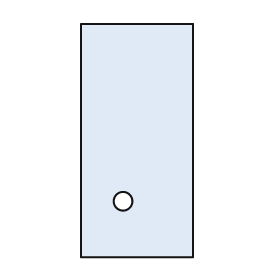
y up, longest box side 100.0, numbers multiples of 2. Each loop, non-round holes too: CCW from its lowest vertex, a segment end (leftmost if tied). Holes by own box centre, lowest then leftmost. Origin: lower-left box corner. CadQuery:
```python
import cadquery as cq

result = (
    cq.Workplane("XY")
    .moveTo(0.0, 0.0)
    .lineTo(48.0, 0.0)
    .lineTo(48.0, 100.0)
    .lineTo(0.0, 100.0)
    .close()
    .moveTo(18.0, 24.0)
    .circle(4.0)
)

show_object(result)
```